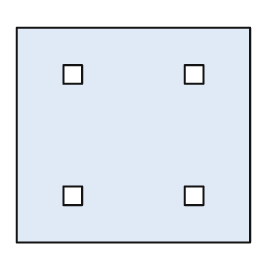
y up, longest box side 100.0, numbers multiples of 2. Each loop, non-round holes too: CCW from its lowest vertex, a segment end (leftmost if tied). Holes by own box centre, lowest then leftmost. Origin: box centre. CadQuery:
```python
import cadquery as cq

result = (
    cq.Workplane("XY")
    .moveTo(-50.0, -46.0)
    .lineTo(50.0, -46.0)
    .lineTo(50.0, 46.0)
    .lineTo(-50.0, 46.0)
    .close()
    .moveTo(-30.0, -30.0)
    .lineTo(-22.0, -30.0)
    .lineTo(-22.0, -22.0)
    .lineTo(-30.0, -22.0)
    .close()
    .moveTo(22.0, -30.0)
    .lineTo(30.0, -30.0)
    .lineTo(30.0, -22.0)
    .lineTo(22.0, -22.0)
    .close()
    .moveTo(-30.0, 22.0)
    .lineTo(-22.0, 22.0)
    .lineTo(-22.0, 30.0)
    .lineTo(-30.0, 30.0)
    .close()
    .moveTo(22.0, 22.0)
    .lineTo(30.0, 22.0)
    .lineTo(30.0, 30.0)
    .lineTo(22.0, 30.0)
    .close()
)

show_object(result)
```